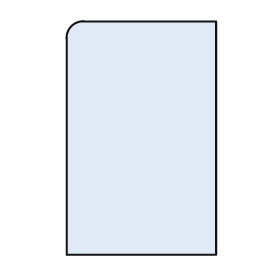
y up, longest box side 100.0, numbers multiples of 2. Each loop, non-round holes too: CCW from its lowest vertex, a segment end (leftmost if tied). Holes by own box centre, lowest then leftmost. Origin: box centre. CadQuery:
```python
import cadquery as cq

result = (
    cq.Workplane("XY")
    .moveTo(-32.0, -50.0)
    .lineTo(32.0, -50.0)
    .lineTo(32.0, 50.0)
    .lineTo(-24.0, 50.0)
    .threePointArc((-30.0, 48.0), (-32.0, 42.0))
    .close()
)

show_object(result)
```